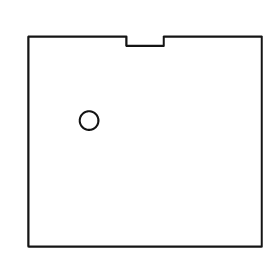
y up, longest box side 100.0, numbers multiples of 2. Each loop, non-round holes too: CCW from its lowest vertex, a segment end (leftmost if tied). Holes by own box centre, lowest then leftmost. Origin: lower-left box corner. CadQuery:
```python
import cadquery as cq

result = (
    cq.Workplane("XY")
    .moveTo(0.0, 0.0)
    .lineTo(100.0, 0.0)
    .lineTo(100.0, 90.0)
    .lineTo(58.0, 90.0)
    .lineTo(58.0, 86.0)
    .lineTo(42.0, 86.0)
    .lineTo(42.0, 90.0)
    .lineTo(0.0, 90.0)
    .close()
    .moveTo(26.0, 54.0)
    .circle(4.0)
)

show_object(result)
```